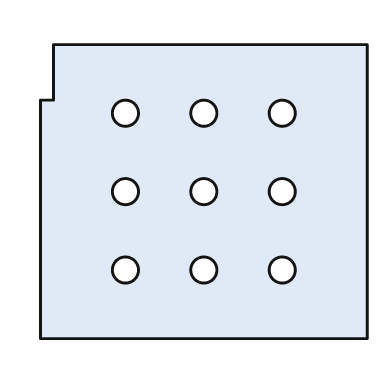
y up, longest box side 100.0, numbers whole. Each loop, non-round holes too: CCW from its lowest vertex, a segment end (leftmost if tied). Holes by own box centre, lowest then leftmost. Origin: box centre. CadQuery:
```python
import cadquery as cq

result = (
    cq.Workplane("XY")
    .moveTo(-50.0, -45.0)
    .lineTo(50.0, -45.0)
    .lineTo(50.0, 45.0)
    .lineTo(-46.0, 45.0)
    .lineTo(-46.0, 28.0)
    .lineTo(-50.0, 28.0)
    .close()
    .moveTo(-24.0, -24.0)
    .circle(4.0)
    .moveTo(0.0, -24.0)
    .circle(4.0)
    .moveTo(24.0, -24.0)
    .circle(4.0)
    .moveTo(-24.0, 0.0)
    .circle(4.0)
    .moveTo(0.0, 0.0)
    .circle(4.0)
    .moveTo(24.0, 0.0)
    .circle(4.0)
    .moveTo(-24.0, 24.0)
    .circle(4.0)
    .moveTo(0.0, 24.0)
    .circle(4.0)
    .moveTo(24.0, 24.0)
    .circle(4.0)
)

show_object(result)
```